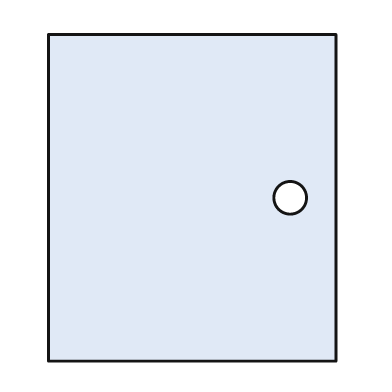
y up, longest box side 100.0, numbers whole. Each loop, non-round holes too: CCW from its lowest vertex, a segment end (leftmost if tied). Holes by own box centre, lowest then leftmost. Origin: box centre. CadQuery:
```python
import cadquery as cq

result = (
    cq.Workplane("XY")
    .moveTo(-44.0, -50.0)
    .lineTo(44.0, -50.0)
    .lineTo(44.0, 50.0)
    .lineTo(-44.0, 50.0)
    .close()
    .moveTo(30.0, 0.0)
    .circle(5.0)
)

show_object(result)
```